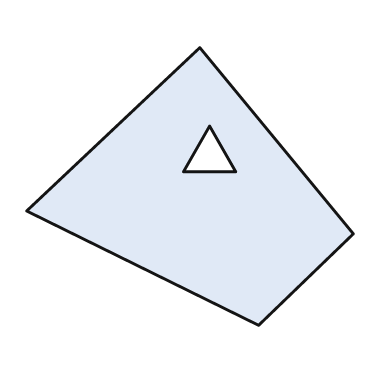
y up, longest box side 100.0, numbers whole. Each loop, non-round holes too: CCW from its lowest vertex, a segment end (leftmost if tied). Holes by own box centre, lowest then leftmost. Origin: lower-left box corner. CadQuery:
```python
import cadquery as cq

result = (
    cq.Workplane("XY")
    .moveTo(71.0, 0.0)
    .lineTo(100.0, 28.0)
    .lineTo(53.0, 85.0)
    .lineTo(0.0, 35.0)
    .close()
    .moveTo(48.0, 47.0)
    .lineTo(64.0, 47.0)
    .lineTo(56.0, 61.0)
    .close()
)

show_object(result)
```